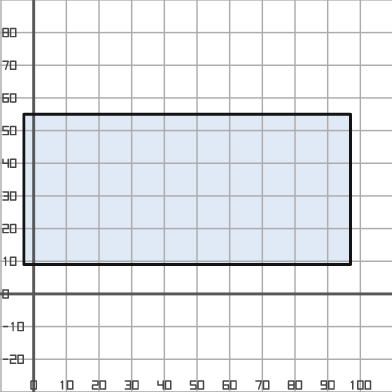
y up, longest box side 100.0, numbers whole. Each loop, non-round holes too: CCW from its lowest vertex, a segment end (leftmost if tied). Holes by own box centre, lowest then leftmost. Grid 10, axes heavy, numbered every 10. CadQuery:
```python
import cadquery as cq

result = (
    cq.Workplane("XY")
    .moveTo(-3.0, 9.0)
    .lineTo(97.0, 9.0)
    .lineTo(97.0, 55.0)
    .lineTo(-3.0, 55.0)
    .close()
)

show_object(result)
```